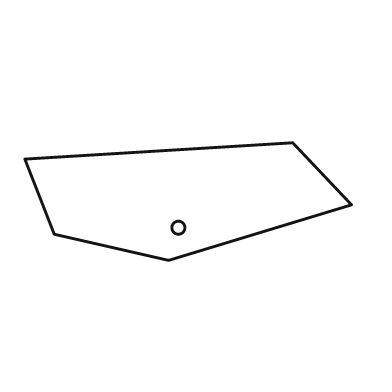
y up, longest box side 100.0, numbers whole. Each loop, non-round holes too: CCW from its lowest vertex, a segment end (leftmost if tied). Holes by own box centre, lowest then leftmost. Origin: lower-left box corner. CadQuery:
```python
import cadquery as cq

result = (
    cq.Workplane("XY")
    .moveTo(44.0, 0.0)
    .lineTo(100.0, 17.0)
    .lineTo(82.0, 36.0)
    .lineTo(0.0, 31.0)
    .lineTo(9.0, 8.0)
    .close()
    .moveTo(47.0, 10.0)
    .circle(2.0)
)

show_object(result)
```